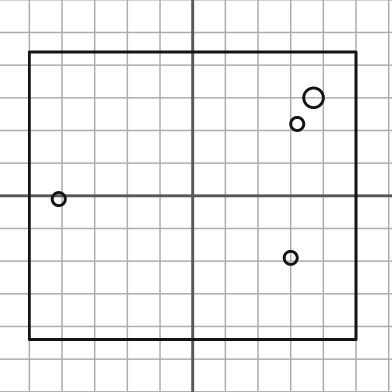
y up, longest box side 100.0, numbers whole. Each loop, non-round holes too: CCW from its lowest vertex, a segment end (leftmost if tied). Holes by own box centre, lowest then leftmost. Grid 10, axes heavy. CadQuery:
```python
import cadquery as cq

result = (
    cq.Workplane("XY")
    .moveTo(-50.0, -44.0)
    .lineTo(50.0, -44.0)
    .lineTo(50.0, 44.0)
    .lineTo(-50.0, 44.0)
    .close()
    .moveTo(30.0, -19.0)
    .circle(2.0)
    .moveTo(-41.0, -1.0)
    .circle(2.0)
    .moveTo(32.0, 22.0)
    .circle(2.0)
    .moveTo(37.0, 30.0)
    .circle(3.0)
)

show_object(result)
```